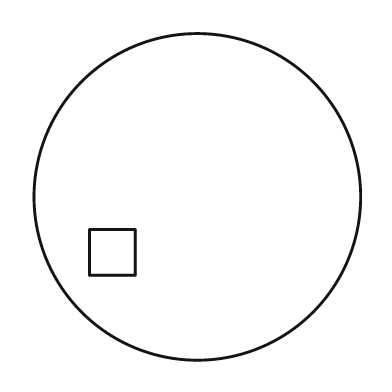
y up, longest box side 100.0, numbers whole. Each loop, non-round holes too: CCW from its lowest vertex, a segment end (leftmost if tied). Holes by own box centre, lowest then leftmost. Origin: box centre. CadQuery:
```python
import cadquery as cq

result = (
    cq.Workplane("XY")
    .moveTo(0.0, 0.0)
    .circle(50.0)
    .moveTo(-33.0, -24.0)
    .lineTo(-19.0, -24.0)
    .lineTo(-19.0, -10.0)
    .lineTo(-33.0, -10.0)
    .close()
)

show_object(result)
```